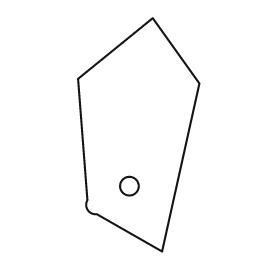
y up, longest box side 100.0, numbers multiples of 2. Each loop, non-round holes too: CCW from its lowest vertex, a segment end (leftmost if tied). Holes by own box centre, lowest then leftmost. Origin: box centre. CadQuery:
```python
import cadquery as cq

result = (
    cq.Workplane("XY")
    .moveTo(10.0, -50.0)
    .lineTo(26.0, 22.0)
    .lineTo(6.0, 50.0)
    .lineTo(-26.0, 24.0)
    .lineTo(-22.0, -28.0)
    .threePointArc((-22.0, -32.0), (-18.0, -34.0))
    .close()
    .moveTo(-4.0, -22.0)
    .circle(4.0)
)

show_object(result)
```